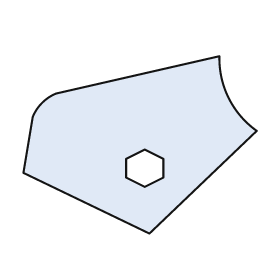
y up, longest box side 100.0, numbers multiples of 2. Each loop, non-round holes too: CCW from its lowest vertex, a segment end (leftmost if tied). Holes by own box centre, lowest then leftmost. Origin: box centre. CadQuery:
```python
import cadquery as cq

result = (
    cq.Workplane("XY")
    .moveTo(4.0, -38.0)
    .lineTo(50.0, 6.0)
    .threePointArc((38.0, 20.0), (34.0, 38.0))
    .lineTo(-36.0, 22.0)
    .threePointArc((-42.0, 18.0), (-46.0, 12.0))
    .lineTo(-50.0, -12.0)
    .close()
    .moveTo(2.0, -18.0)
    .lineTo(10.0, -14.0)
    .lineTo(10.0, -6.0)
    .lineTo(2.0, -2.0)
    .lineTo(-6.0, -6.0)
    .lineTo(-6.0, -14.0)
    .close()
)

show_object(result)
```